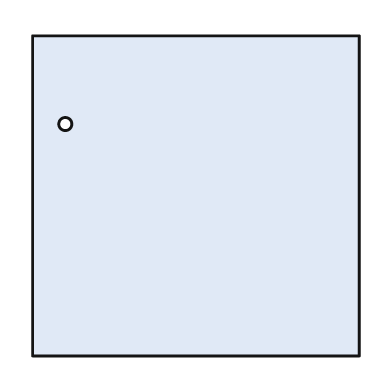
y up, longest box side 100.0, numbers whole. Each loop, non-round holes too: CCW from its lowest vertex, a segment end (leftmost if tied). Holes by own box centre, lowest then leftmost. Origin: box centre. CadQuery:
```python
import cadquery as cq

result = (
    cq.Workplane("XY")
    .moveTo(-50.0, -49.0)
    .lineTo(50.0, -49.0)
    .lineTo(50.0, 49.0)
    .lineTo(-50.0, 49.0)
    .close()
    .moveTo(-40.0, 22.0)
    .circle(2.0)
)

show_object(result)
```